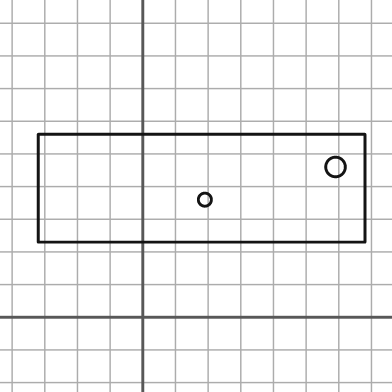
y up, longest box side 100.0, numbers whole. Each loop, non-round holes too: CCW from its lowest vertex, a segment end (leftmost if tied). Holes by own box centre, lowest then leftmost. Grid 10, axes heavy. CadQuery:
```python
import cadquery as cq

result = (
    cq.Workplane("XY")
    .moveTo(-32.0, 23.0)
    .lineTo(68.0, 23.0)
    .lineTo(68.0, 56.0)
    .lineTo(-32.0, 56.0)
    .close()
    .moveTo(19.0, 36.0)
    .circle(2.0)
    .moveTo(59.0, 46.0)
    .circle(3.0)
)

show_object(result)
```